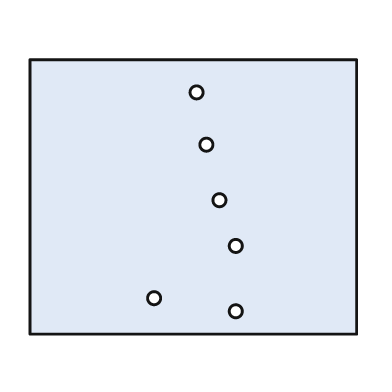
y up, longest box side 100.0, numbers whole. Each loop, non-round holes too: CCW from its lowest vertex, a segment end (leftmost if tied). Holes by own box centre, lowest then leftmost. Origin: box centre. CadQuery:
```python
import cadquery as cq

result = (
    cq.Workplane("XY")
    .moveTo(-50.0, -42.0)
    .lineTo(50.0, -42.0)
    .lineTo(50.0, 42.0)
    .lineTo(-50.0, 42.0)
    .close()
    .moveTo(13.0, -35.0)
    .circle(2.0)
    .moveTo(-12.0, -31.0)
    .circle(2.0)
    .moveTo(13.0, -15.0)
    .circle(2.0)
    .moveTo(8.0, -1.0)
    .circle(2.0)
    .moveTo(4.0, 16.0)
    .circle(2.0)
    .moveTo(1.0, 32.0)
    .circle(2.0)
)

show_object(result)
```